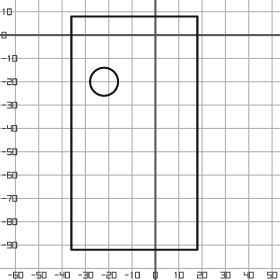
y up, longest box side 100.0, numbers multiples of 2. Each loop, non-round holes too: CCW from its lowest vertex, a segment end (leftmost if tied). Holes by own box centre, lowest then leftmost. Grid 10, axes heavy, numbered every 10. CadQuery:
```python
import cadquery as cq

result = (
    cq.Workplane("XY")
    .moveTo(-36.0, -92.0)
    .lineTo(18.0, -92.0)
    .lineTo(18.0, 8.0)
    .lineTo(-36.0, 8.0)
    .close()
    .moveTo(-22.0, -20.0)
    .circle(6.0)
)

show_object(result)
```